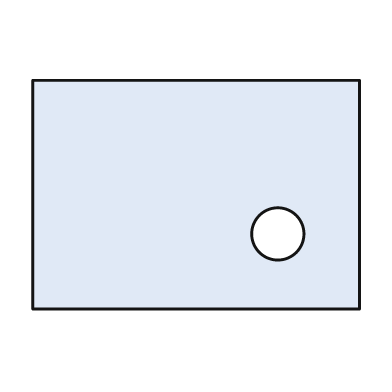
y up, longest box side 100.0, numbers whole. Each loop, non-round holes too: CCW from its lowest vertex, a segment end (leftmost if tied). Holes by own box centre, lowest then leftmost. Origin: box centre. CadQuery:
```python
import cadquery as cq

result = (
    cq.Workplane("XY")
    .moveTo(-50.0, -35.0)
    .lineTo(50.0, -35.0)
    .lineTo(50.0, 35.0)
    .lineTo(-50.0, 35.0)
    .close()
    .moveTo(25.0, -12.0)
    .circle(8.0)
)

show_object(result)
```